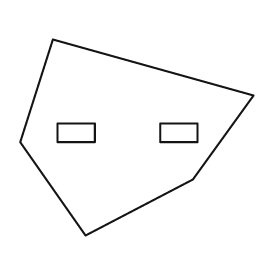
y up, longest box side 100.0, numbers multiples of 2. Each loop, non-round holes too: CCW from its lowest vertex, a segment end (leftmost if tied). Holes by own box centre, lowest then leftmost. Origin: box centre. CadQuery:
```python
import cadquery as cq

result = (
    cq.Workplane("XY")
    .moveTo(-22.0, -42.0)
    .lineTo(24.0, -18.0)
    .lineTo(50.0, 18.0)
    .lineTo(-36.0, 42.0)
    .lineTo(-50.0, -2.0)
    .close()
    .moveTo(-34.0, -2.0)
    .lineTo(-18.0, -2.0)
    .lineTo(-18.0, 6.0)
    .lineTo(-34.0, 6.0)
    .close()
    .moveTo(10.0, -2.0)
    .lineTo(26.0, -2.0)
    .lineTo(26.0, 6.0)
    .lineTo(10.0, 6.0)
    .close()
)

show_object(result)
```